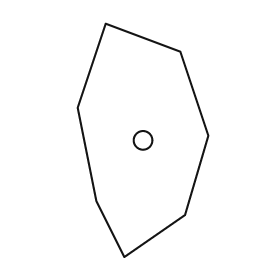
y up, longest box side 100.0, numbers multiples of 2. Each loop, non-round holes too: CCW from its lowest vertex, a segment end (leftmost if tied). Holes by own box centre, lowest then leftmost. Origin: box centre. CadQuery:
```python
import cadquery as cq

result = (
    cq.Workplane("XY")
    .moveTo(-8.0, -50.0)
    .lineTo(18.0, -32.0)
    .lineTo(28.0, 2.0)
    .lineTo(16.0, 38.0)
    .lineTo(-16.0, 50.0)
    .lineTo(-28.0, 14.0)
    .lineTo(-20.0, -26.0)
    .close()
    .moveTo(0.0, 0.0)
    .circle(4.0)
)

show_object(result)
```